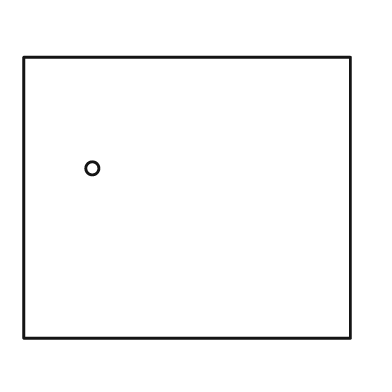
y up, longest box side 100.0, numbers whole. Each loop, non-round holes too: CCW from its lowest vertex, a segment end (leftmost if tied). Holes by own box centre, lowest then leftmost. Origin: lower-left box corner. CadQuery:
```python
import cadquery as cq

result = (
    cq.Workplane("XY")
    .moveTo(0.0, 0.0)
    .lineTo(100.0, 0.0)
    .lineTo(100.0, 86.0)
    .lineTo(0.0, 86.0)
    .close()
    .moveTo(21.0, 52.0)
    .circle(2.0)
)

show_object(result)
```